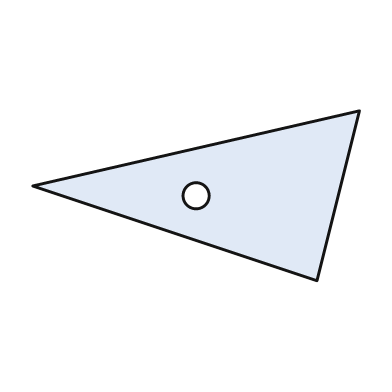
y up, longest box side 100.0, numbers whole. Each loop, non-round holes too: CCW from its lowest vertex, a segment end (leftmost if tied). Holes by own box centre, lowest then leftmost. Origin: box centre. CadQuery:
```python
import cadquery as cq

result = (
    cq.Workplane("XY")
    .moveTo(37.0, -26.0)
    .lineTo(50.0, 26.0)
    .lineTo(-50.0, 3.0)
    .close()
    .moveTo(0.0, 0.0)
    .circle(4.0)
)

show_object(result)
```